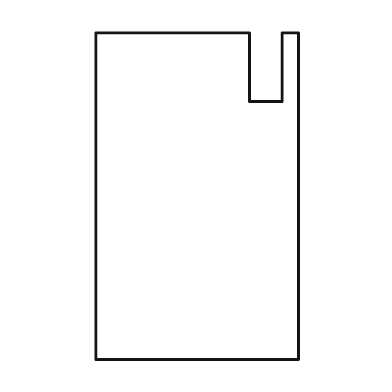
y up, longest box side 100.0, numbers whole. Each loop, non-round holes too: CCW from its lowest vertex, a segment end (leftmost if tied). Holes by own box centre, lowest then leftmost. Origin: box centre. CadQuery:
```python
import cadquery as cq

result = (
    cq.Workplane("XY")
    .moveTo(-31.0, -50.0)
    .lineTo(31.0, -50.0)
    .lineTo(31.0, 50.0)
    .lineTo(26.0, 50.0)
    .lineTo(26.0, 29.0)
    .lineTo(16.0, 29.0)
    .lineTo(16.0, 50.0)
    .lineTo(-31.0, 50.0)
    .close()
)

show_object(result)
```